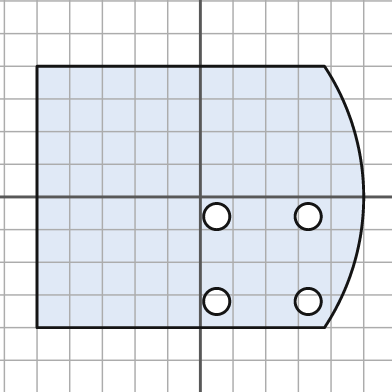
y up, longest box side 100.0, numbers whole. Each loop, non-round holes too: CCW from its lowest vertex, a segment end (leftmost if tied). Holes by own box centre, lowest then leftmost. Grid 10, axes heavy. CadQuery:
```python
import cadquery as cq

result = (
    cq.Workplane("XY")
    .moveTo(-50.0, -40.0)
    .lineTo(38.0, -40.0)
    .threePointArc((50.0, 0.0), (38.0, 40.0))
    .lineTo(-50.0, 40.0)
    .close()
    .moveTo(5.0, -32.0)
    .circle(4.0)
    .moveTo(33.0, -32.0)
    .circle(4.0)
    .moveTo(5.0, -6.0)
    .circle(4.0)
    .moveTo(33.0, -6.0)
    .circle(4.0)
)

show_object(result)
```